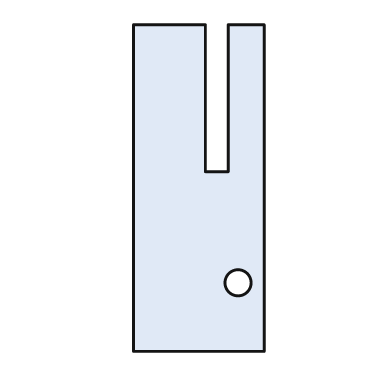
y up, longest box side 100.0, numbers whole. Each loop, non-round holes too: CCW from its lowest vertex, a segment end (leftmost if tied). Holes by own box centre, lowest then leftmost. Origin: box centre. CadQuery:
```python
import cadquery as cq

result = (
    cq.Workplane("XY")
    .moveTo(-20.0, -50.0)
    .lineTo(20.0, -50.0)
    .lineTo(20.0, 50.0)
    .lineTo(9.0, 50.0)
    .lineTo(9.0, 5.0)
    .lineTo(2.0, 5.0)
    .lineTo(2.0, 50.0)
    .lineTo(-20.0, 50.0)
    .close()
    .moveTo(12.0, -29.0)
    .circle(4.0)
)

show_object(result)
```